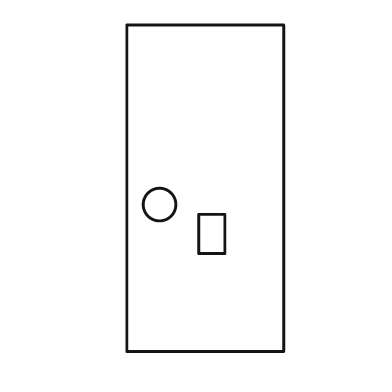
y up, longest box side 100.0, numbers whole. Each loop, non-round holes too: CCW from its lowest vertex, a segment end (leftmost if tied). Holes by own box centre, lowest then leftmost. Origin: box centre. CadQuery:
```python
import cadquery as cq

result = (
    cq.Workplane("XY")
    .moveTo(-24.0, -50.0)
    .lineTo(24.0, -50.0)
    .lineTo(24.0, 50.0)
    .lineTo(-24.0, 50.0)
    .close()
    .moveTo(-2.0, -20.0)
    .lineTo(6.0, -20.0)
    .lineTo(6.0, -8.0)
    .lineTo(-2.0, -8.0)
    .close()
    .moveTo(-14.0, -5.0)
    .circle(5.0)
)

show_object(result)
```